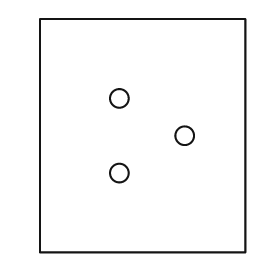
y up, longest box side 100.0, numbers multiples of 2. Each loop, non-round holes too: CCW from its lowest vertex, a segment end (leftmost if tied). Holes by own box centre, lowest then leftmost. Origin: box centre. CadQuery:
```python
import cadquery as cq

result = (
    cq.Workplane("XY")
    .moveTo(-44.0, -50.0)
    .lineTo(44.0, -50.0)
    .lineTo(44.0, 50.0)
    .lineTo(-44.0, 50.0)
    .close()
    .moveTo(-10.0, -16.0)
    .circle(4.0)
    .moveTo(18.0, 0.0)
    .circle(4.0)
    .moveTo(-10.0, 16.0)
    .circle(4.0)
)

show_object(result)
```